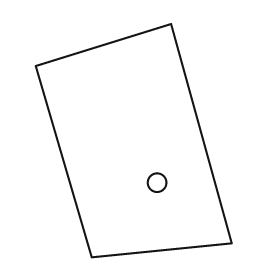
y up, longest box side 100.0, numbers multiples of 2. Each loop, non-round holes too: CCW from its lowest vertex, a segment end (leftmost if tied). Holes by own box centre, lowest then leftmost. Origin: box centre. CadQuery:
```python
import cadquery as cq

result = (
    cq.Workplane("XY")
    .moveTo(-18.0, -50.0)
    .lineTo(42.0, -44.0)
    .lineTo(16.0, 50.0)
    .lineTo(-42.0, 32.0)
    .close()
    .moveTo(10.0, -18.0)
    .circle(4.0)
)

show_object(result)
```